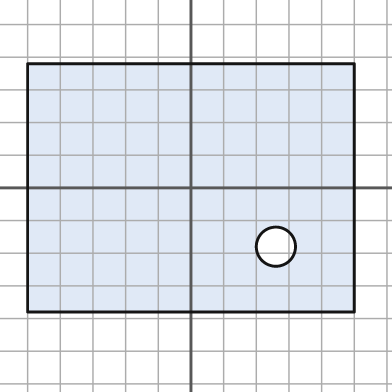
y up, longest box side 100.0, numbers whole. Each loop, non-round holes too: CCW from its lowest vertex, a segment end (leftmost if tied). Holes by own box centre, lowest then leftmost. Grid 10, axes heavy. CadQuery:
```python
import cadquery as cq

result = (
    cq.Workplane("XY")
    .moveTo(-50.0, -38.0)
    .lineTo(50.0, -38.0)
    .lineTo(50.0, 38.0)
    .lineTo(-50.0, 38.0)
    .close()
    .moveTo(26.0, -18.0)
    .circle(6.0)
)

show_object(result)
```